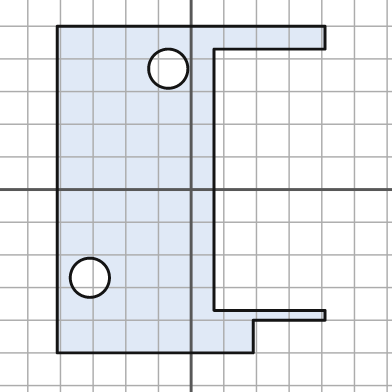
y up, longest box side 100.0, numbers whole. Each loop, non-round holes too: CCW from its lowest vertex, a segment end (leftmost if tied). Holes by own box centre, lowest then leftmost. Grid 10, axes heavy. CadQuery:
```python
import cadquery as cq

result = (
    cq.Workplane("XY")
    .moveTo(-41.0, -50.0)
    .lineTo(19.0, -50.0)
    .lineTo(19.0, -40.0)
    .lineTo(41.0, -40.0)
    .lineTo(41.0, -37.0)
    .lineTo(7.0, -37.0)
    .lineTo(7.0, 43.0)
    .lineTo(41.0, 43.0)
    .lineTo(41.0, 50.0)
    .lineTo(-41.0, 50.0)
    .close()
    .moveTo(-31.0, -27.0)
    .circle(6.0)
    .moveTo(-7.0, 37.0)
    .circle(6.0)
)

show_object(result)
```